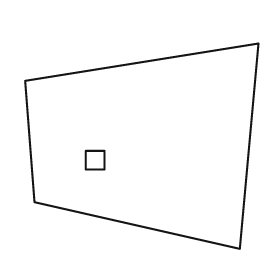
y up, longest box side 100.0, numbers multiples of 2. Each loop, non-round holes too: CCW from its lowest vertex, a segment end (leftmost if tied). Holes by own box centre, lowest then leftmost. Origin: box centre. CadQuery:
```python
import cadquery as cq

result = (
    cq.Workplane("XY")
    .moveTo(42.0, -44.0)
    .lineTo(50.0, 44.0)
    .lineTo(-50.0, 28.0)
    .lineTo(-46.0, -24.0)
    .close()
    .moveTo(-24.0, -10.0)
    .lineTo(-16.0, -10.0)
    .lineTo(-16.0, -2.0)
    .lineTo(-24.0, -2.0)
    .close()
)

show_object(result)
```